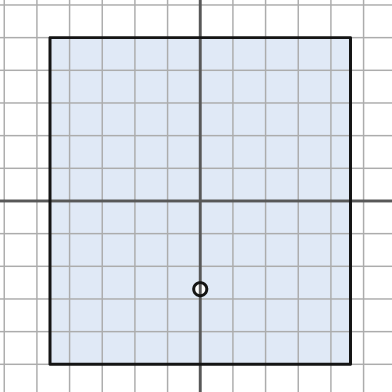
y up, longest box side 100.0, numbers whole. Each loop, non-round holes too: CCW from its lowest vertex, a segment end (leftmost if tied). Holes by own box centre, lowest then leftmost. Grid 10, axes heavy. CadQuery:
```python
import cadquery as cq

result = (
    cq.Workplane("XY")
    .moveTo(-46.0, -50.0)
    .lineTo(46.0, -50.0)
    .lineTo(46.0, 50.0)
    .lineTo(-46.0, 50.0)
    .close()
    .moveTo(0.0, -27.0)
    .circle(2.0)
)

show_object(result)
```